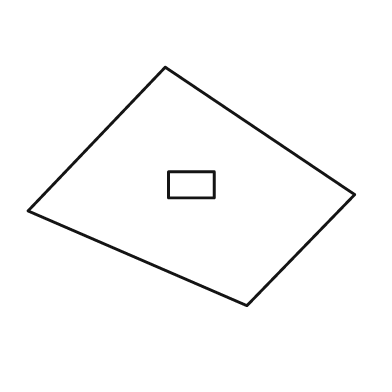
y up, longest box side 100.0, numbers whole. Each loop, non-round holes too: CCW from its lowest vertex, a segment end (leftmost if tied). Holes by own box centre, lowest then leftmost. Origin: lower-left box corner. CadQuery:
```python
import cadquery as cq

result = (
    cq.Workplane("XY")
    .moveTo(67.0, 0.0)
    .lineTo(100.0, 34.0)
    .lineTo(42.0, 73.0)
    .lineTo(0.0, 29.0)
    .close()
    .moveTo(43.0, 33.0)
    .lineTo(57.0, 33.0)
    .lineTo(57.0, 41.0)
    .lineTo(43.0, 41.0)
    .close()
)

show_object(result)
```